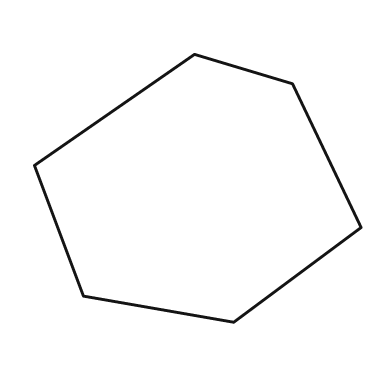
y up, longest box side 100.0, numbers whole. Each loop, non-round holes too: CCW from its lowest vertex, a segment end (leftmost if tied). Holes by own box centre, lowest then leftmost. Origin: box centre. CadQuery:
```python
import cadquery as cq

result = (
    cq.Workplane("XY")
    .moveTo(11.0, -41.0)
    .lineTo(50.0, -12.0)
    .lineTo(29.0, 32.0)
    .lineTo(-1.0, 41.0)
    .lineTo(-50.0, 7.0)
    .lineTo(-35.0, -33.0)
    .close()
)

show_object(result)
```